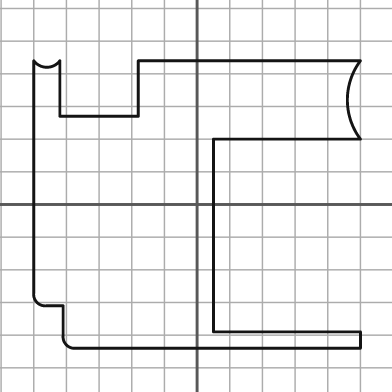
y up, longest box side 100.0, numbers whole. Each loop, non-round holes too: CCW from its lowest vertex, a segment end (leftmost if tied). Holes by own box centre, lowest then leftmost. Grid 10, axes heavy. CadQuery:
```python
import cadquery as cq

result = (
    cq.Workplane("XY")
    .moveTo(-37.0, -44.0)
    .lineTo(50.0, -44.0)
    .lineTo(50.0, -39.0)
    .lineTo(5.0, -39.0)
    .lineTo(5.0, 20.0)
    .lineTo(50.0, 20.0)
    .threePointArc((46.0, 32.0), (50.0, 44.0))
    .lineTo(-18.0, 44.0)
    .lineTo(-18.0, 27.0)
    .lineTo(-42.0, 27.0)
    .lineTo(-42.0, 44.0)
    .threePointArc((-46.0, 42.0), (-50.0, 44.0))
    .lineTo(-50.0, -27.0)
    .threePointArc((-49.0, -30.0), (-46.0, -31.0))
    .lineTo(-41.0, -31.0)
    .lineTo(-41.0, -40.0)
    .threePointArc((-40.0, -43.0), (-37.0, -44.0))
    .close()
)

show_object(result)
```